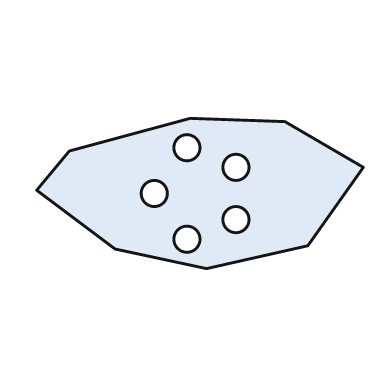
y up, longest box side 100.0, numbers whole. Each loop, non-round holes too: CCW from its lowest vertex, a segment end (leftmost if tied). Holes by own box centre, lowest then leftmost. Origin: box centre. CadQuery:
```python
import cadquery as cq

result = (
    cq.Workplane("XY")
    .moveTo(2.0, -23.0)
    .lineTo(33.0, -16.0)
    .lineTo(50.0, 8.0)
    .lineTo(26.0, 22.0)
    .lineTo(-3.0, 23.0)
    .lineTo(-40.0, 13.0)
    .lineTo(-50.0, 1.0)
    .lineTo(-26.0, -17.0)
    .close()
    .moveTo(-4.0, -14.0)
    .circle(4.0)
    .moveTo(11.0, -8.0)
    .circle(4.0)
    .moveTo(-14.0, 0.0)
    .circle(4.0)
    .moveTo(11.0, 8.0)
    .circle(4.0)
    .moveTo(-4.0, 14.0)
    .circle(4.0)
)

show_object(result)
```